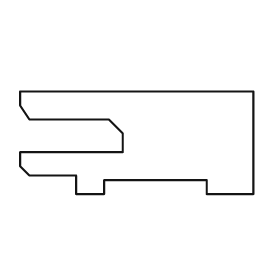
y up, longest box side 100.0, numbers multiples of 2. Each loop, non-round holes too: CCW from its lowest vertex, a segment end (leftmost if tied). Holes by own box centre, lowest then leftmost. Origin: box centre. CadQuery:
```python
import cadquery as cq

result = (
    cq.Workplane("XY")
    .moveTo(-26.0, -22.0)
    .lineTo(-14.0, -22.0)
    .lineTo(-14.0, -16.0)
    .lineTo(30.0, -16.0)
    .lineTo(30.0, -22.0)
    .lineTo(50.0, -22.0)
    .lineTo(50.0, 22.0)
    .lineTo(-50.0, 22.0)
    .lineTo(-50.0, 16.0)
    .lineTo(-46.0, 10.0)
    .lineTo(-12.0, 10.0)
    .lineTo(-6.0, 4.0)
    .lineTo(-6.0, -4.0)
    .lineTo(-50.0, -4.0)
    .lineTo(-50.0, -10.0)
    .lineTo(-46.0, -14.0)
    .lineTo(-26.0, -14.0)
    .close()
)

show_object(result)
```